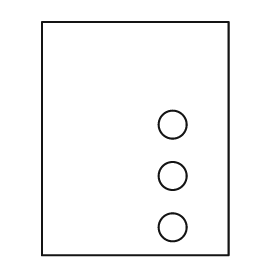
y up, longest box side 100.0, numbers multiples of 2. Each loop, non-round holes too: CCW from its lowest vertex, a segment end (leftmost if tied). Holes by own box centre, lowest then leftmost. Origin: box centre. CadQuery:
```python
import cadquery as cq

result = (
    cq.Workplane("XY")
    .moveTo(-40.0, -50.0)
    .lineTo(40.0, -50.0)
    .lineTo(40.0, 50.0)
    .lineTo(-40.0, 50.0)
    .close()
    .moveTo(16.0, -38.0)
    .circle(6.0)
    .moveTo(16.0, -16.0)
    .circle(6.0)
    .moveTo(16.0, 6.0)
    .circle(6.0)
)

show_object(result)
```